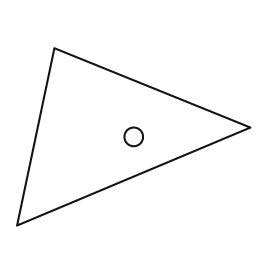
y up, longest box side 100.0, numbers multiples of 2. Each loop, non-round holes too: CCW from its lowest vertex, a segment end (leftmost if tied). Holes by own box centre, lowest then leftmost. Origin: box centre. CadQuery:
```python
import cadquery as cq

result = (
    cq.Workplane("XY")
    .moveTo(-50.0, -38.0)
    .lineTo(50.0, 4.0)
    .lineTo(-34.0, 38.0)
    .close()
    .moveTo(0.0, 0.0)
    .circle(4.0)
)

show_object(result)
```